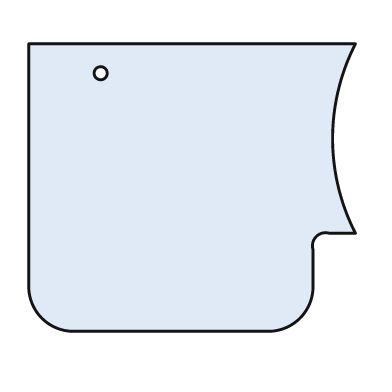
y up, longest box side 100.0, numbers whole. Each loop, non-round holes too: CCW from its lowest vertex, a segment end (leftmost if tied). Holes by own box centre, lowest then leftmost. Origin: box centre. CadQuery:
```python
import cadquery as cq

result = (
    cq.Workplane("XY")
    .moveTo(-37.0, -44.0)
    .lineTo(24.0, -44.0)
    .threePointArc((33.0, -40.0), (37.0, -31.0))
    .lineTo(37.0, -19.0)
    .threePointArc((38.0, -15.0), (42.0, -14.0))
    .lineTo(50.0, -14.0)
    .threePointArc((43.0, 15.0), (50.0, 44.0))
    .lineTo(-50.0, 44.0)
    .lineTo(-50.0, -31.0)
    .threePointArc((-46.0, -40.0), (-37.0, -44.0))
    .close()
    .moveTo(-28.0, 35.0)
    .circle(2.0)
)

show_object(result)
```